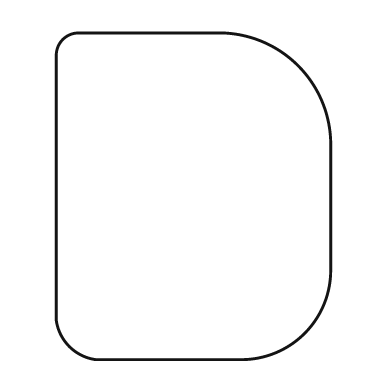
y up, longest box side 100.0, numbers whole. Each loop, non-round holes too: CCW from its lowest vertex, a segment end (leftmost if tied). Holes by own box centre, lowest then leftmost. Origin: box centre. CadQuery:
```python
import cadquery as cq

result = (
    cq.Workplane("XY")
    .moveTo(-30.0, -50.0)
    .lineTo(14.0, -50.0)
    .threePointArc((34.0, -42.0), (42.0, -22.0))
    .lineTo(42.0, 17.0)
    .threePointArc((32.0, 40.0), (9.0, 50.0))
    .lineTo(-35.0, 50.0)
    .threePointArc((-40.0, 48.0), (-42.0, 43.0))
    .lineTo(-42.0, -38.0)
    .threePointArc((-38.0, -46.0), (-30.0, -50.0))
    .close()
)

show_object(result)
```